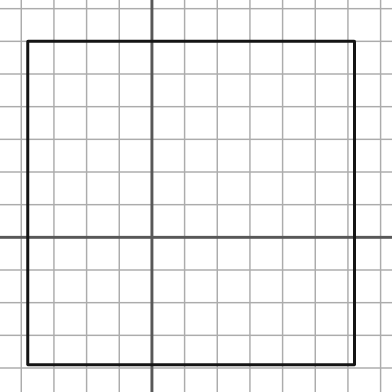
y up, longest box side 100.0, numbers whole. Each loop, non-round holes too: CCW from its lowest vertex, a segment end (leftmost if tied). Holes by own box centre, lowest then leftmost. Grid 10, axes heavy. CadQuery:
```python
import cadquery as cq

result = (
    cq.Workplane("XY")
    .moveTo(-38.0, -39.0)
    .lineTo(62.0, -39.0)
    .lineTo(62.0, 60.0)
    .lineTo(-38.0, 60.0)
    .close()
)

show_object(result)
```